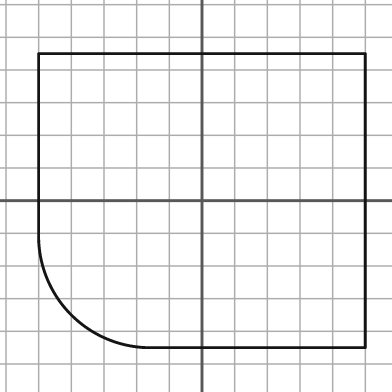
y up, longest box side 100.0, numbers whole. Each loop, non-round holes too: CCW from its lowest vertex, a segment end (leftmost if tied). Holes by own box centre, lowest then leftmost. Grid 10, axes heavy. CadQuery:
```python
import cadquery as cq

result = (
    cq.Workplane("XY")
    .moveTo(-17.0, -45.0)
    .lineTo(50.0, -45.0)
    .lineTo(50.0, 45.0)
    .lineTo(-50.0, 45.0)
    .lineTo(-50.0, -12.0)
    .threePointArc((-40.0, -35.0), (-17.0, -45.0))
    .close()
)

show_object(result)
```